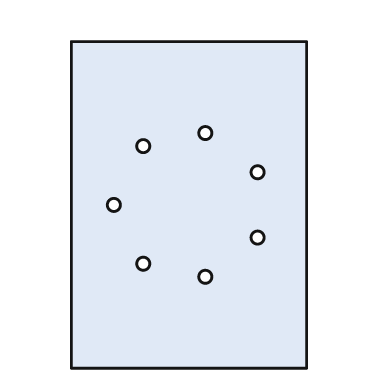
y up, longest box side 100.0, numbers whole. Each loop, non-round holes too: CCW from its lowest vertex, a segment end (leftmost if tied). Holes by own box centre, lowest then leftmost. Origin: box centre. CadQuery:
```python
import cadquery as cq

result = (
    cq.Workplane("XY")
    .moveTo(-36.0, -50.0)
    .lineTo(36.0, -50.0)
    .lineTo(36.0, 50.0)
    .lineTo(-36.0, 50.0)
    .close()
    .moveTo(5.0, -22.0)
    .circle(2.0)
    .moveTo(-14.0, -18.0)
    .circle(2.0)
    .moveTo(21.0, -10.0)
    .circle(2.0)
    .moveTo(-23.0, 0.0)
    .circle(2.0)
    .moveTo(21.0, 10.0)
    .circle(2.0)
    .moveTo(-14.0, 18.0)
    .circle(2.0)
    .moveTo(5.0, 22.0)
    .circle(2.0)
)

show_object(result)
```